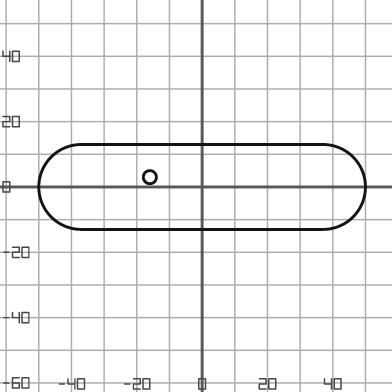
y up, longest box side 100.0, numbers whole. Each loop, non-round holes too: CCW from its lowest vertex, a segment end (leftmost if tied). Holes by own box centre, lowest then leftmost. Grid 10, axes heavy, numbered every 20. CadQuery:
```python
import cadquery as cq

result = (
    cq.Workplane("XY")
    .moveTo(-37.0, -13.0)
    .lineTo(37.0, -13.0)
    .threePointArc((50.0, 0.0), (37.0, 13.0))
    .lineTo(-37.0, 13.0)
    .threePointArc((-50.0, 0.0), (-37.0, -13.0))
    .close()
    .moveTo(-16.0, 3.0)
    .circle(2.0)
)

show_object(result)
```